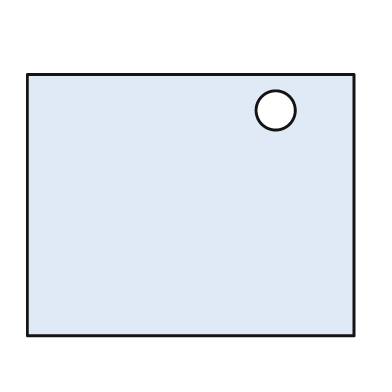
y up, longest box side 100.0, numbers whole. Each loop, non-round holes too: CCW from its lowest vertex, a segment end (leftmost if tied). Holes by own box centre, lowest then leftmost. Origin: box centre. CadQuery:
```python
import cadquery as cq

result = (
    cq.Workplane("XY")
    .moveTo(-50.0, -40.0)
    .lineTo(50.0, -40.0)
    .lineTo(50.0, 40.0)
    .lineTo(-50.0, 40.0)
    .close()
    .moveTo(26.0, 29.0)
    .circle(6.0)
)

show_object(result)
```